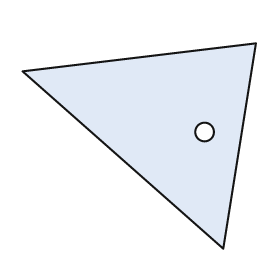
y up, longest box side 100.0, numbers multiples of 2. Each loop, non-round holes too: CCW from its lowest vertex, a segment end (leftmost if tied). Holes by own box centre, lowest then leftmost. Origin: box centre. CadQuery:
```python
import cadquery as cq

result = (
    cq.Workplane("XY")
    .moveTo(36.0, -44.0)
    .lineTo(50.0, 44.0)
    .lineTo(-50.0, 32.0)
    .close()
    .moveTo(28.0, 6.0)
    .circle(4.0)
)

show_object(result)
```